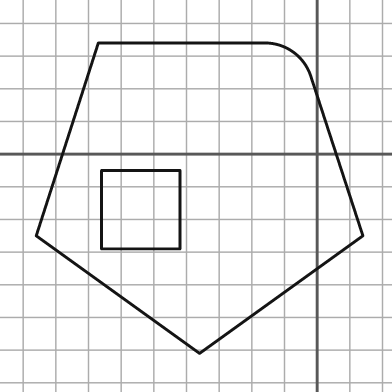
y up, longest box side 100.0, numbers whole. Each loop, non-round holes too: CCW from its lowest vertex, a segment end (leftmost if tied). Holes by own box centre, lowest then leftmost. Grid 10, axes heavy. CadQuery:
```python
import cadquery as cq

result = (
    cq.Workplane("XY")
    .moveTo(-36.0, -61.0)
    .lineTo(14.0, -25.0)
    .lineTo(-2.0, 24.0)
    .threePointArc((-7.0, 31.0), (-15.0, 34.0))
    .lineTo(-67.0, 34.0)
    .lineTo(-86.0, -25.0)
    .close()
    .moveTo(-66.0, -29.0)
    .lineTo(-42.0, -29.0)
    .lineTo(-42.0, -5.0)
    .lineTo(-66.0, -5.0)
    .close()
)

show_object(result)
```